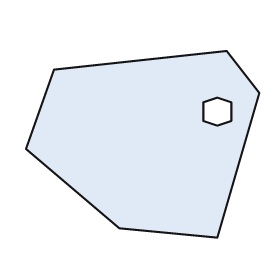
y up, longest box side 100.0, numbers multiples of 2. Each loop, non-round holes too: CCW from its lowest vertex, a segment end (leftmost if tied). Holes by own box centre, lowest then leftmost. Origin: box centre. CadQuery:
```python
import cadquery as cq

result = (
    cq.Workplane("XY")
    .moveTo(32.0, -40.0)
    .lineTo(50.0, 22.0)
    .lineTo(36.0, 40.0)
    .lineTo(-38.0, 32.0)
    .lineTo(-50.0, -2.0)
    .lineTo(-10.0, -36.0)
    .close()
    .moveTo(32.0, 8.0)
    .lineTo(38.0, 10.0)
    .lineTo(38.0, 18.0)
    .lineTo(32.0, 20.0)
    .lineTo(26.0, 18.0)
    .lineTo(26.0, 10.0)
    .close()
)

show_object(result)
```